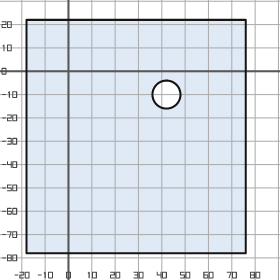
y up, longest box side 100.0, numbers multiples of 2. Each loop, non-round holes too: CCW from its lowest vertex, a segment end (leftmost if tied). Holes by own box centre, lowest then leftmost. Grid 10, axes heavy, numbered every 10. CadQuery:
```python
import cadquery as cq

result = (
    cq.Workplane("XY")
    .moveTo(-18.0, -78.0)
    .lineTo(76.0, -78.0)
    .lineTo(76.0, 22.0)
    .lineTo(-18.0, 22.0)
    .close()
    .moveTo(42.0, -10.0)
    .circle(6.0)
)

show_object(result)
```